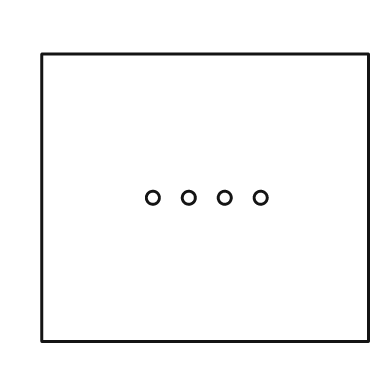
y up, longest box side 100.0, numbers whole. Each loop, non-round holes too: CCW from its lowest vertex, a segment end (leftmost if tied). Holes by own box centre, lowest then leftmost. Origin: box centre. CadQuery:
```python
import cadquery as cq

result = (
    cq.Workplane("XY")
    .moveTo(-50.0, -44.0)
    .lineTo(50.0, -44.0)
    .lineTo(50.0, 44.0)
    .lineTo(-50.0, 44.0)
    .close()
    .moveTo(-16.0, 0.0)
    .circle(2.0)
    .moveTo(-5.0, 0.0)
    .circle(2.0)
    .moveTo(6.0, 0.0)
    .circle(2.0)
    .moveTo(17.0, 0.0)
    .circle(2.0)
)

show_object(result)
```